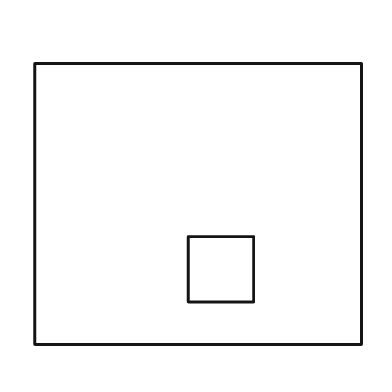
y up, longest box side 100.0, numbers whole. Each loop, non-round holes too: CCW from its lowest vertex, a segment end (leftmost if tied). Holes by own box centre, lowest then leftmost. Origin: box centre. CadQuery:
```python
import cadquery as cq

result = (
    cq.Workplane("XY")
    .moveTo(-50.0, -43.0)
    .lineTo(50.0, -43.0)
    .lineTo(50.0, 43.0)
    .lineTo(-50.0, 43.0)
    .close()
    .moveTo(-3.0, -30.0)
    .lineTo(17.0, -30.0)
    .lineTo(17.0, -10.0)
    .lineTo(-3.0, -10.0)
    .close()
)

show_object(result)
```